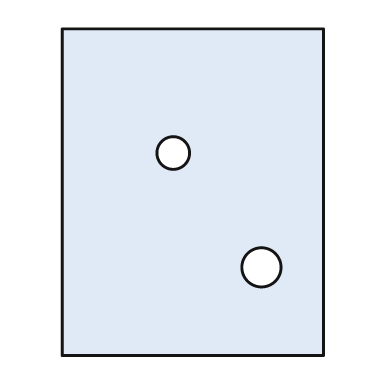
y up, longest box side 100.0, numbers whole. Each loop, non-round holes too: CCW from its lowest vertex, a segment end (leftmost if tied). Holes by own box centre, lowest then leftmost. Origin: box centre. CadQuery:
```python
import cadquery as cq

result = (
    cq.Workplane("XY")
    .moveTo(-40.0, -50.0)
    .lineTo(40.0, -50.0)
    .lineTo(40.0, 50.0)
    .lineTo(-40.0, 50.0)
    .close()
    .moveTo(21.0, -23.0)
    .circle(6.0)
    .moveTo(-6.0, 12.0)
    .circle(5.0)
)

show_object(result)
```